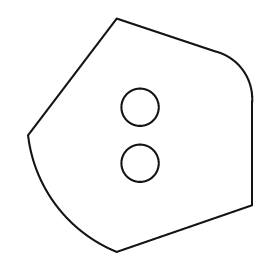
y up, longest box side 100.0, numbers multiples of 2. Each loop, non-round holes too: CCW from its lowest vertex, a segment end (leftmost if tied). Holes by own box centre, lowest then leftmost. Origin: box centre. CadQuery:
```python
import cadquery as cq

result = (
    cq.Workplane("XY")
    .moveTo(-10.0, -50.0)
    .lineTo(48.0, -30.0)
    .lineTo(48.0, 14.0)
    .threePointArc((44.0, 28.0), (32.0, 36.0))
    .lineTo(-10.0, 50.0)
    .lineTo(-48.0, 0.0)
    .threePointArc((-36.0, -30.0), (-10.0, -50.0))
    .close()
    .moveTo(0.0, -12.0)
    .circle(8.0)
    .moveTo(0.0, 12.0)
    .circle(8.0)
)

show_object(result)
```